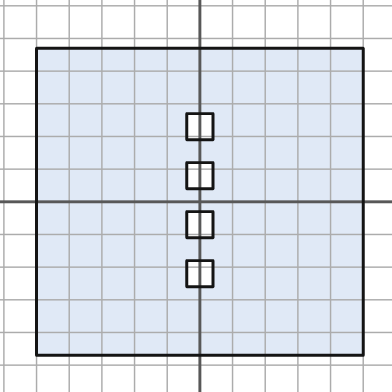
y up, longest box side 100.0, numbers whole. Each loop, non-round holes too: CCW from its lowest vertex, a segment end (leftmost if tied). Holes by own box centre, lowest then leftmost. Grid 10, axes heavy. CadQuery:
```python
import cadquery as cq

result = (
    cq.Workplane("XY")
    .moveTo(-50.0, -47.0)
    .lineTo(50.0, -47.0)
    .lineTo(50.0, 47.0)
    .lineTo(-50.0, 47.0)
    .close()
    .moveTo(-4.0, -26.0)
    .lineTo(4.0, -26.0)
    .lineTo(4.0, -18.0)
    .lineTo(-4.0, -18.0)
    .close()
    .moveTo(-4.0, -11.0)
    .lineTo(4.0, -11.0)
    .lineTo(4.0, -3.0)
    .lineTo(-4.0, -3.0)
    .close()
    .moveTo(-4.0, 4.0)
    .lineTo(4.0, 4.0)
    .lineTo(4.0, 12.0)
    .lineTo(-4.0, 12.0)
    .close()
    .moveTo(-4.0, 19.0)
    .lineTo(4.0, 19.0)
    .lineTo(4.0, 27.0)
    .lineTo(-4.0, 27.0)
    .close()
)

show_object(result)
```